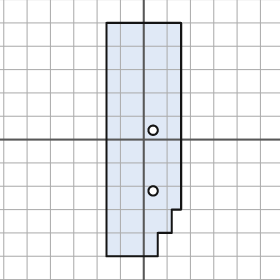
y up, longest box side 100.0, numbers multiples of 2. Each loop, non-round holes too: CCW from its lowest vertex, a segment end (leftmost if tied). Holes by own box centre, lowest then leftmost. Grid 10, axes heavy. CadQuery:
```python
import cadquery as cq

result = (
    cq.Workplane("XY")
    .moveTo(-16.0, -50.0)
    .lineTo(6.0, -50.0)
    .lineTo(6.0, -40.0)
    .lineTo(12.0, -40.0)
    .lineTo(12.0, -30.0)
    .lineTo(16.0, -30.0)
    .lineTo(16.0, 50.0)
    .lineTo(-16.0, 50.0)
    .close()
    .moveTo(4.0, -22.0)
    .circle(2.0)
    .moveTo(4.0, 4.0)
    .circle(2.0)
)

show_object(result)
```